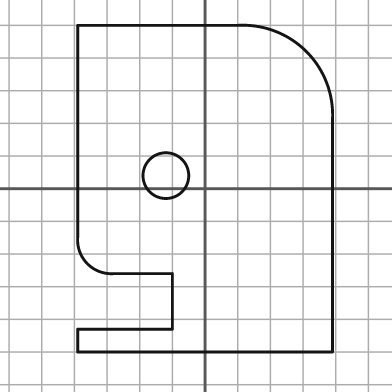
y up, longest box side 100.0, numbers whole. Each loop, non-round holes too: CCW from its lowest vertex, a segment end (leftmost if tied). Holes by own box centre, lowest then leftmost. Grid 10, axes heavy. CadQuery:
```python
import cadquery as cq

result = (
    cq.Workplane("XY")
    .moveTo(-39.0, -50.0)
    .lineTo(39.0, -50.0)
    .lineTo(39.0, 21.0)
    .threePointArc((31.0, 42.0), (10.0, 50.0))
    .lineTo(-39.0, 50.0)
    .lineTo(-39.0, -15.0)
    .threePointArc((-36.0, -23.0), (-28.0, -26.0))
    .lineTo(-10.0, -26.0)
    .lineTo(-10.0, -43.0)
    .lineTo(-39.0, -43.0)
    .close()
    .moveTo(-12.0, 4.0)
    .circle(7.0)
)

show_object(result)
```